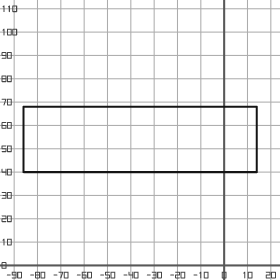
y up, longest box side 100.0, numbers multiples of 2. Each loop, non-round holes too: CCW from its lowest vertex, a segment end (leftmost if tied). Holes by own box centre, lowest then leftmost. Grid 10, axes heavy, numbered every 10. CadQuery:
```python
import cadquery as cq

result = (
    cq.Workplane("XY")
    .moveTo(-86.0, 40.0)
    .lineTo(14.0, 40.0)
    .lineTo(14.0, 68.0)
    .lineTo(-86.0, 68.0)
    .close()
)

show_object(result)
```